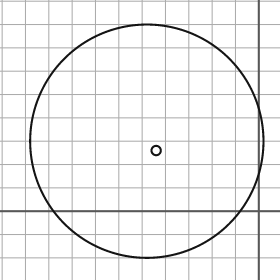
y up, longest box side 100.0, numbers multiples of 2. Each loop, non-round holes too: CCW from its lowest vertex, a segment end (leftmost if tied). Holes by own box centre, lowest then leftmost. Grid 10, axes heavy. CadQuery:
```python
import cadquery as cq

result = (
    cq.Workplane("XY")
    .moveTo(-48.0, 30.0)
    .circle(50.0)
    .moveTo(-44.0, 26.0)
    .circle(2.0)
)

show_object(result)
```